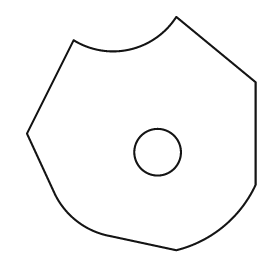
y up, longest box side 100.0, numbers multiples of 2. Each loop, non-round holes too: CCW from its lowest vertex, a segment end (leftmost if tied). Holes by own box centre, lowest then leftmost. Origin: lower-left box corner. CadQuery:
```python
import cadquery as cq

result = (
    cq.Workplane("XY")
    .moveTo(64.0, 0.0)
    .threePointArc((84.0, 10.0), (98.0, 28.0))
    .lineTo(98.0, 72.0)
    .lineTo(64.0, 100.0)
    .threePointArc((44.0, 86.0), (20.0, 90.0))
    .lineTo(0.0, 50.0)
    .lineTo(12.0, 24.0)
    .threePointArc((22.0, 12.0), (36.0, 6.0))
    .close()
    .moveTo(56.0, 42.0)
    .circle(10.0)
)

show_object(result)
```